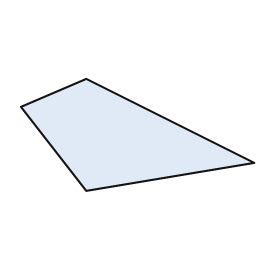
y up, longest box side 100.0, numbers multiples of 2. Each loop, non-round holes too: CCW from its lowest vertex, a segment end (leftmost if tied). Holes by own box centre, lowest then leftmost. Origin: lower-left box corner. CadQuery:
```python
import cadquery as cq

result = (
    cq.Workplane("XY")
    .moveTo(28.0, 0.0)
    .lineTo(100.0, 12.0)
    .lineTo(28.0, 48.0)
    .lineTo(0.0, 36.0)
    .close()
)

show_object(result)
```